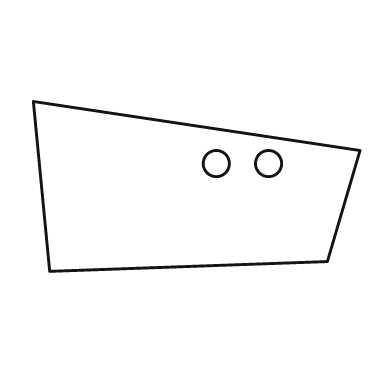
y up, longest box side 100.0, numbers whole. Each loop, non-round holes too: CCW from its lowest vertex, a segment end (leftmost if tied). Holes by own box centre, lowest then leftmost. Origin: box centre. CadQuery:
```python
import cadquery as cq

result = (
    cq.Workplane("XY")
    .moveTo(-45.0, -26.0)
    .lineTo(40.0, -23.0)
    .lineTo(50.0, 11.0)
    .lineTo(-50.0, 26.0)
    .close()
    .moveTo(6.0, 7.0)
    .circle(4.0)
    .moveTo(22.0, 7.0)
    .circle(4.0)
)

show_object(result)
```